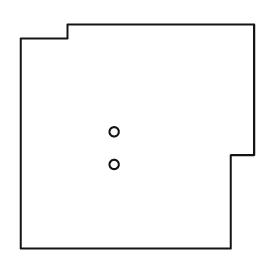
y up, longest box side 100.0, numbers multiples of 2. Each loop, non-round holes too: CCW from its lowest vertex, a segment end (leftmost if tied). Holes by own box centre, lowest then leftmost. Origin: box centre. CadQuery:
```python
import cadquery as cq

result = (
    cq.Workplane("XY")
    .moveTo(-50.0, -48.0)
    .lineTo(40.0, -48.0)
    .lineTo(40.0, -8.0)
    .lineTo(50.0, -8.0)
    .lineTo(50.0, 48.0)
    .lineTo(-30.0, 48.0)
    .lineTo(-30.0, 42.0)
    .lineTo(-50.0, 42.0)
    .close()
    .moveTo(-10.0, -12.0)
    .circle(2.0)
    .moveTo(-10.0, 2.0)
    .circle(2.0)
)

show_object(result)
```